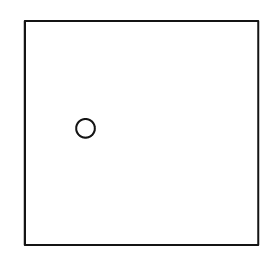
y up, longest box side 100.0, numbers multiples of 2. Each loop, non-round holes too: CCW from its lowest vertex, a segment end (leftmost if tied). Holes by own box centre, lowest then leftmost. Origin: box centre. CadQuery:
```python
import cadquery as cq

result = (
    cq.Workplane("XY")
    .moveTo(-50.0, -48.0)
    .lineTo(50.0, -48.0)
    .lineTo(50.0, 48.0)
    .lineTo(-50.0, 48.0)
    .close()
    .moveTo(-24.0, 2.0)
    .circle(4.0)
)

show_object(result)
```